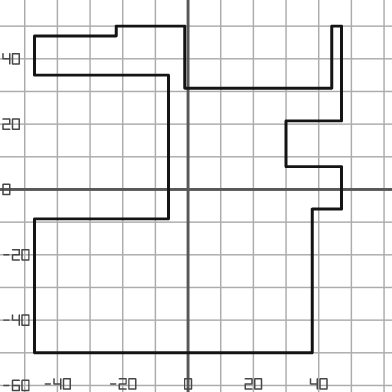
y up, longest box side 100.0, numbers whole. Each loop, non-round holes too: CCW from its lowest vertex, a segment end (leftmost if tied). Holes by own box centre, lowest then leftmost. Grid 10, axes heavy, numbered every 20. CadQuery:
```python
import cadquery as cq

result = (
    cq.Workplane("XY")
    .moveTo(-47.0, -50.0)
    .lineTo(38.0, -50.0)
    .lineTo(38.0, -6.0)
    .lineTo(47.0, -6.0)
    .lineTo(47.0, 7.0)
    .lineTo(30.0, 7.0)
    .lineTo(30.0, 21.0)
    .lineTo(47.0, 21.0)
    .lineTo(47.0, 50.0)
    .lineTo(44.0, 50.0)
    .lineTo(44.0, 31.0)
    .lineTo(-1.0, 31.0)
    .lineTo(-1.0, 50.0)
    .lineTo(-22.0, 50.0)
    .lineTo(-22.0, 47.0)
    .lineTo(-47.0, 47.0)
    .lineTo(-47.0, 35.0)
    .lineTo(-6.0, 35.0)
    .lineTo(-6.0, -9.0)
    .lineTo(-47.0, -9.0)
    .close()
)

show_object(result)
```